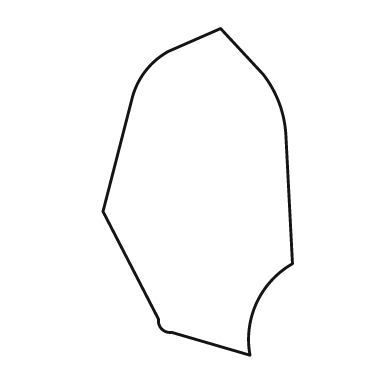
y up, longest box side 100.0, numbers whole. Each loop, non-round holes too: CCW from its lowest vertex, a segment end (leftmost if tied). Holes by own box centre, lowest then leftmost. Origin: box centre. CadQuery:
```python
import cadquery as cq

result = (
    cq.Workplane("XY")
    .moveTo(16.0, -50.0)
    .threePointArc((18.0, -34.0), (29.0, -22.0))
    .lineTo(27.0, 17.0)
    .threePointArc((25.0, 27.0), (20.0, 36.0))
    .lineTo(7.0, 50.0)
    .lineTo(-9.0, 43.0)
    .threePointArc((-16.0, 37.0), (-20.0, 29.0))
    .lineTo(-29.0, -6.0)
    .lineTo(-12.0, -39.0)
    .threePointArc((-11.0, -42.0), (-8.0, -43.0))
    .close()
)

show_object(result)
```